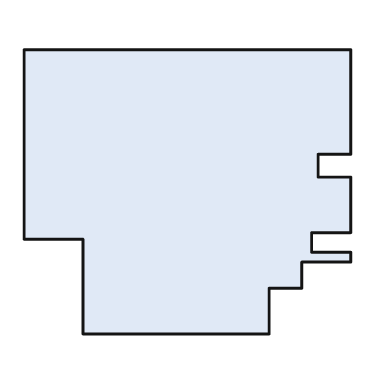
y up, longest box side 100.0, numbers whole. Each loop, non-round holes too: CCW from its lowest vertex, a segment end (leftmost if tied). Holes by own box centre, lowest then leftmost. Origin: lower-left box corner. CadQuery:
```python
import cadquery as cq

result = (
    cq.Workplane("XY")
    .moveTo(18.0, 0.0)
    .lineTo(75.0, 0.0)
    .lineTo(75.0, 14.0)
    .lineTo(85.0, 14.0)
    .lineTo(85.0, 22.0)
    .lineTo(100.0, 22.0)
    .lineTo(100.0, 25.0)
    .lineTo(88.0, 25.0)
    .lineTo(88.0, 31.0)
    .lineTo(100.0, 31.0)
    .lineTo(100.0, 48.0)
    .lineTo(90.0, 48.0)
    .lineTo(90.0, 55.0)
    .lineTo(100.0, 55.0)
    .lineTo(100.0, 87.0)
    .lineTo(0.0, 87.0)
    .lineTo(0.0, 29.0)
    .lineTo(18.0, 29.0)
    .close()
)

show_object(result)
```